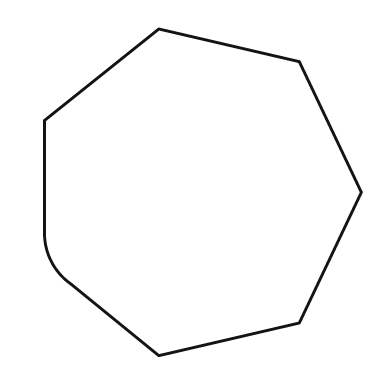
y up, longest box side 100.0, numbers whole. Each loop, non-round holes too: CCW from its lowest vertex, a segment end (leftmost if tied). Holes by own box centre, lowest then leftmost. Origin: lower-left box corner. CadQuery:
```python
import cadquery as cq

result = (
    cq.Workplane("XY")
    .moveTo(35.0, 0.0)
    .lineTo(78.0, 10.0)
    .lineTo(97.0, 50.0)
    .lineTo(78.0, 90.0)
    .lineTo(35.0, 100.0)
    .lineTo(0.0, 72.0)
    .lineTo(0.0, 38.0)
    .threePointArc((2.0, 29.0), (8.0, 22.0))
    .close()
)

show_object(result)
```